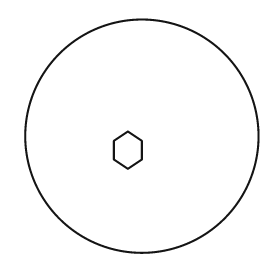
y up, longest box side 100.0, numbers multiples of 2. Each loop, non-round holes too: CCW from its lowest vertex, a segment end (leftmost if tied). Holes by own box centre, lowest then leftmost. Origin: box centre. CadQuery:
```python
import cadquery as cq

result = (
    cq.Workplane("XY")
    .moveTo(0.0, 0.0)
    .circle(50.0)
    .moveTo(-6.0, -14.0)
    .lineTo(0.0, -10.0)
    .lineTo(0.0, -2.0)
    .lineTo(-6.0, 2.0)
    .lineTo(-12.0, -2.0)
    .lineTo(-12.0, -10.0)
    .close()
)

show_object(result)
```